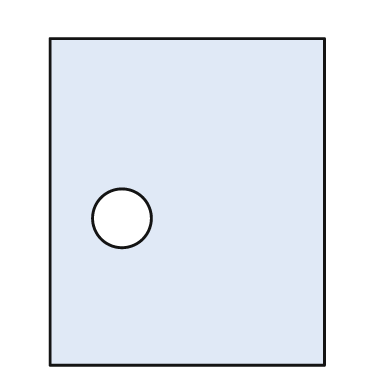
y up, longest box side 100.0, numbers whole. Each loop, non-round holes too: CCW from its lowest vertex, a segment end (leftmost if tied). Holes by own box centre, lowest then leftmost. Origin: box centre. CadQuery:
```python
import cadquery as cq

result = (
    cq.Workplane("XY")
    .moveTo(-42.0, -50.0)
    .lineTo(42.0, -50.0)
    .lineTo(42.0, 50.0)
    .lineTo(-42.0, 50.0)
    .close()
    .moveTo(-20.0, -5.0)
    .circle(9.0)
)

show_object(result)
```